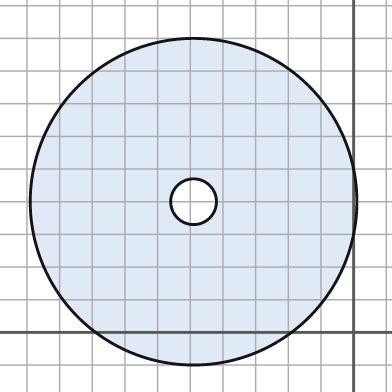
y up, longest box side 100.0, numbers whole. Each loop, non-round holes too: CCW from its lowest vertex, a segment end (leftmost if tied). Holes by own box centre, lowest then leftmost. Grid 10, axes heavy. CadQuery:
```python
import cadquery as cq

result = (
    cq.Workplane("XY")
    .moveTo(-49.0, 40.0)
    .circle(50.0)
    .moveTo(-49.0, 40.0)
    .circle(7.0)
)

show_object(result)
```